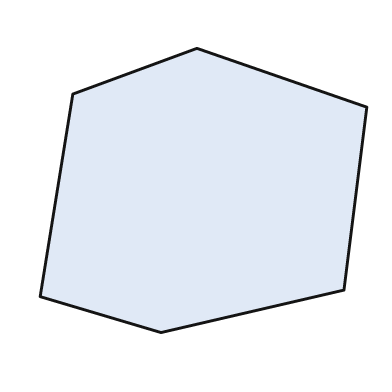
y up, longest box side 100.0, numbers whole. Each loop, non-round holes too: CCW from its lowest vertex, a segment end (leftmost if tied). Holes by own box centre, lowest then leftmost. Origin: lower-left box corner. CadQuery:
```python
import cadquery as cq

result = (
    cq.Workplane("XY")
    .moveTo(37.0, 0.0)
    .lineTo(93.0, 13.0)
    .lineTo(100.0, 69.0)
    .lineTo(48.0, 87.0)
    .lineTo(10.0, 73.0)
    .lineTo(0.0, 11.0)
    .close()
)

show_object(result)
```